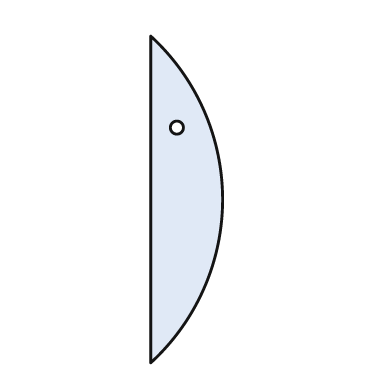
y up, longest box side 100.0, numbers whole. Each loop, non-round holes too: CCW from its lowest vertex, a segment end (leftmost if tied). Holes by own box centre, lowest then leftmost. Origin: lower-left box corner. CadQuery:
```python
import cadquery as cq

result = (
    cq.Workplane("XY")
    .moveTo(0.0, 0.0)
    .threePointArc((22.0, 50.0), (0.0, 100.0))
    .close()
    .moveTo(8.0, 72.0)
    .circle(2.0)
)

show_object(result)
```